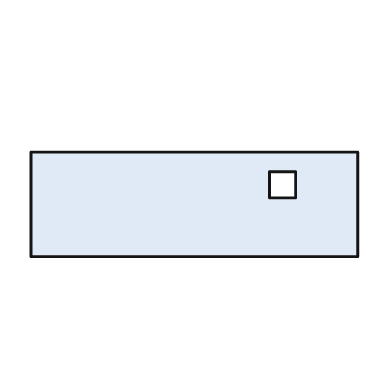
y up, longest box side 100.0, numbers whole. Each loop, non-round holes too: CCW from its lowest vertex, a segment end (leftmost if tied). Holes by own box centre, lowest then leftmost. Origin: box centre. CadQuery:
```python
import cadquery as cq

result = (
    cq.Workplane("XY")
    .moveTo(-50.0, -16.0)
    .lineTo(50.0, -16.0)
    .lineTo(50.0, 16.0)
    .lineTo(-50.0, 16.0)
    .close()
    .moveTo(23.0, 2.0)
    .lineTo(31.0, 2.0)
    .lineTo(31.0, 10.0)
    .lineTo(23.0, 10.0)
    .close()
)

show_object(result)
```